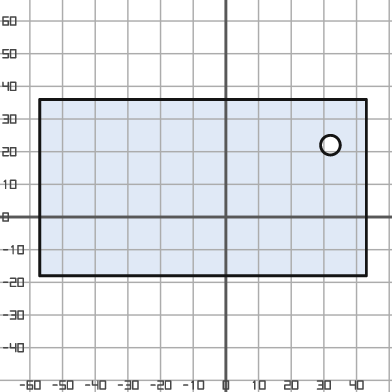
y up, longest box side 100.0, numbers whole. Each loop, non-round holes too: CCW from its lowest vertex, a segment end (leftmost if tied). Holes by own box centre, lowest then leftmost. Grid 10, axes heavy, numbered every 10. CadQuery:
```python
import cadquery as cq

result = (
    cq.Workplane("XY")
    .moveTo(-57.0, -18.0)
    .lineTo(43.0, -18.0)
    .lineTo(43.0, 36.0)
    .lineTo(-57.0, 36.0)
    .close()
    .moveTo(32.0, 22.0)
    .circle(3.0)
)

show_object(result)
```